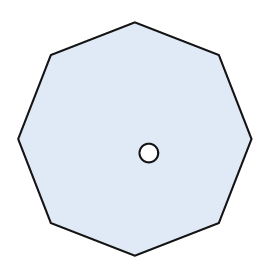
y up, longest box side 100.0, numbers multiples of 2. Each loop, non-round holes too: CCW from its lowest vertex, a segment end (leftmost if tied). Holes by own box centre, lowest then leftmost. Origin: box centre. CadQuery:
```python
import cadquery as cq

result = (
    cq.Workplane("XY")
    .moveTo(0.0, -50.0)
    .lineTo(36.0, -36.0)
    .lineTo(50.0, 0.0)
    .lineTo(36.0, 36.0)
    .lineTo(0.0, 50.0)
    .lineTo(-36.0, 36.0)
    .lineTo(-50.0, 0.0)
    .lineTo(-36.0, -36.0)
    .close()
    .moveTo(6.0, -6.0)
    .circle(4.0)
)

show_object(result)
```